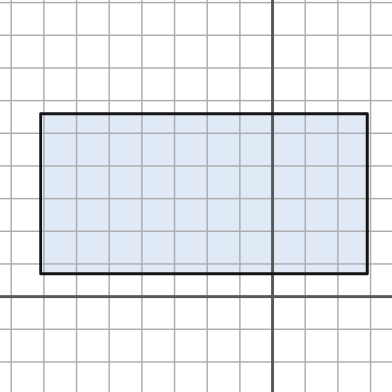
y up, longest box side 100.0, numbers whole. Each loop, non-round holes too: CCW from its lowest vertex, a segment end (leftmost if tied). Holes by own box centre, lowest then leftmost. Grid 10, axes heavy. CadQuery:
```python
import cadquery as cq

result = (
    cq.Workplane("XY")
    .moveTo(-71.0, 7.0)
    .lineTo(29.0, 7.0)
    .lineTo(29.0, 56.0)
    .lineTo(-71.0, 56.0)
    .close()
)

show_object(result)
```